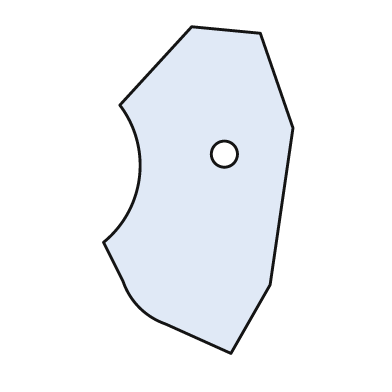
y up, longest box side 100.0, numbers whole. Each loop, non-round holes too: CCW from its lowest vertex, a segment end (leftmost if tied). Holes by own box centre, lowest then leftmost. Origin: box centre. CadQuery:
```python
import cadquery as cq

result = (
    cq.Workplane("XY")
    .moveTo(10.0, -50.0)
    .lineTo(22.0, -29.0)
    .lineTo(29.0, 19.0)
    .lineTo(19.0, 48.0)
    .lineTo(-2.0, 50.0)
    .lineTo(-24.0, 26.0)
    .threePointArc((-18.0, 4.0), (-29.0, -16.0))
    .lineTo(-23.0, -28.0)
    .threePointArc((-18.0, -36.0), (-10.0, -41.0))
    .close()
    .moveTo(8.0, 11.0)
    .circle(4.0)
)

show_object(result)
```